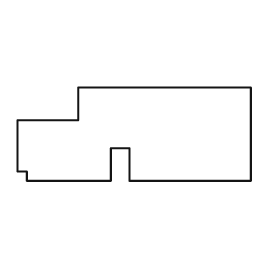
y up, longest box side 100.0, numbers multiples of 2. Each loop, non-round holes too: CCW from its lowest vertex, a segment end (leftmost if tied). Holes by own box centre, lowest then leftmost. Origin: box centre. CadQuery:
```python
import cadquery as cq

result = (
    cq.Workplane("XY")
    .moveTo(-46.0, -20.0)
    .lineTo(-10.0, -20.0)
    .lineTo(-10.0, -6.0)
    .lineTo(-2.0, -6.0)
    .lineTo(-2.0, -20.0)
    .lineTo(50.0, -20.0)
    .lineTo(50.0, 20.0)
    .lineTo(-24.0, 20.0)
    .lineTo(-24.0, 6.0)
    .lineTo(-50.0, 6.0)
    .lineTo(-50.0, -16.0)
    .lineTo(-46.0, -16.0)
    .close()
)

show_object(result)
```